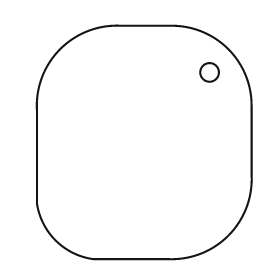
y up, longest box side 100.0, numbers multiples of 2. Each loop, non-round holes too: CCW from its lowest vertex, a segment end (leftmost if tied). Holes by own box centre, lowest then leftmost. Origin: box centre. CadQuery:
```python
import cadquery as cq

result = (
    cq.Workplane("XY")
    .moveTo(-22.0, -50.0)
    .lineTo(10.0, -50.0)
    .threePointArc((36.0, -40.0), (46.0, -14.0))
    .lineTo(46.0, 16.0)
    .threePointArc((36.0, 40.0), (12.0, 50.0))
    .lineTo(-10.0, 50.0)
    .threePointArc((-36.0, 40.0), (-46.0, 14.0))
    .lineTo(-46.0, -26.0)
    .threePointArc((-38.0, -42.0), (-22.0, -50.0))
    .close()
    .moveTo(28.0, 30.0)
    .circle(4.0)
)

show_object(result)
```